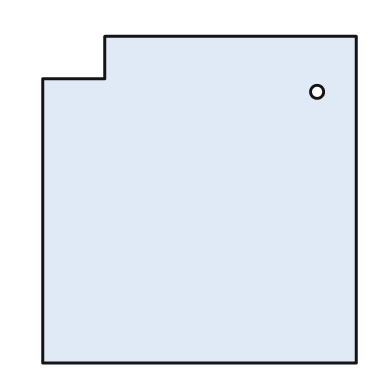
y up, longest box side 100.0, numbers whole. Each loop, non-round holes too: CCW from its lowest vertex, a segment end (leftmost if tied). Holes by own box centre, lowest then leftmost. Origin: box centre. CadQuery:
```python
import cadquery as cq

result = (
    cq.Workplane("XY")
    .moveTo(-48.0, -50.0)
    .lineTo(48.0, -50.0)
    .lineTo(48.0, 50.0)
    .lineTo(-29.0, 50.0)
    .lineTo(-29.0, 37.0)
    .lineTo(-48.0, 37.0)
    .close()
    .moveTo(36.0, 33.0)
    .circle(2.0)
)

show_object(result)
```